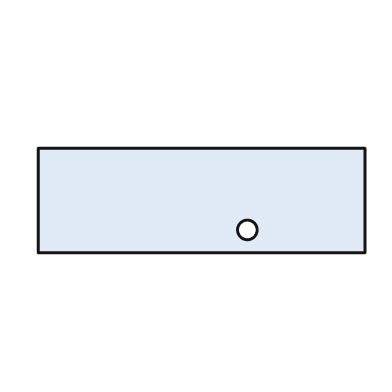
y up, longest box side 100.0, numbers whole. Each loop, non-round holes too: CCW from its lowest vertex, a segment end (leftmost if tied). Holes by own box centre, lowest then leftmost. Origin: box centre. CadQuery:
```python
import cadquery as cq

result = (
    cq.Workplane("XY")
    .moveTo(-50.0, -16.0)
    .lineTo(50.0, -16.0)
    .lineTo(50.0, 16.0)
    .lineTo(-50.0, 16.0)
    .close()
    .moveTo(14.0, -9.0)
    .circle(3.0)
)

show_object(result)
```